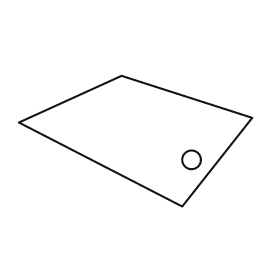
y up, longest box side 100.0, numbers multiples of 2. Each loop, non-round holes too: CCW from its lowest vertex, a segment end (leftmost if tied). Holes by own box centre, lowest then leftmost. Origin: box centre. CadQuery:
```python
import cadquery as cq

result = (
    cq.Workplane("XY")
    .moveTo(20.0, -28.0)
    .lineTo(50.0, 10.0)
    .lineTo(-6.0, 28.0)
    .lineTo(-50.0, 8.0)
    .close()
    .moveTo(24.0, -8.0)
    .circle(4.0)
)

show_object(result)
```